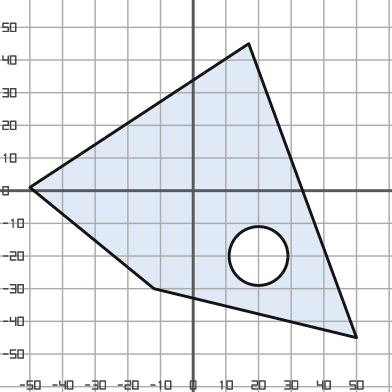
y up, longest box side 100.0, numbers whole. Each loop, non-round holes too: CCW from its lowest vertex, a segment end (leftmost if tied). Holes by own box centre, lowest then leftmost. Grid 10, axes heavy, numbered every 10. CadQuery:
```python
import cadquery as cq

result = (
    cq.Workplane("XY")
    .moveTo(50.0, -45.0)
    .lineTo(17.0, 45.0)
    .lineTo(-50.0, 1.0)
    .lineTo(-12.0, -30.0)
    .close()
    .moveTo(20.0, -20.0)
    .circle(9.0)
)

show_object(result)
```